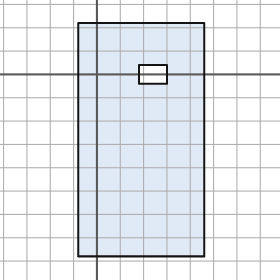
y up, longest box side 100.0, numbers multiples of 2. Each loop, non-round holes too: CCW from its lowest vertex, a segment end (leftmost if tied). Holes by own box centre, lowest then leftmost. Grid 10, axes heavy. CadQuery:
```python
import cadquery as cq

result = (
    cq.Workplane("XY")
    .moveTo(-8.0, -78.0)
    .lineTo(46.0, -78.0)
    .lineTo(46.0, 22.0)
    .lineTo(-8.0, 22.0)
    .close()
    .moveTo(18.0, -4.0)
    .lineTo(30.0, -4.0)
    .lineTo(30.0, 4.0)
    .lineTo(18.0, 4.0)
    .close()
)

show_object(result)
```